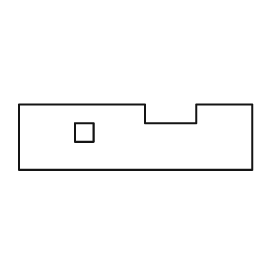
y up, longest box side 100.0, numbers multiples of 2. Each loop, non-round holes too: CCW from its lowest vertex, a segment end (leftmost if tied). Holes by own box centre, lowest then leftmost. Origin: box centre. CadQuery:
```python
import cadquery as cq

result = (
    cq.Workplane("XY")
    .moveTo(-50.0, -14.0)
    .lineTo(50.0, -14.0)
    .lineTo(50.0, 14.0)
    .lineTo(26.0, 14.0)
    .lineTo(26.0, 6.0)
    .lineTo(4.0, 6.0)
    .lineTo(4.0, 14.0)
    .lineTo(-50.0, 14.0)
    .close()
    .moveTo(-26.0, -2.0)
    .lineTo(-18.0, -2.0)
    .lineTo(-18.0, 6.0)
    .lineTo(-26.0, 6.0)
    .close()
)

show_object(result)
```